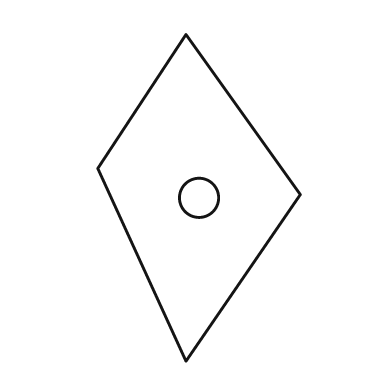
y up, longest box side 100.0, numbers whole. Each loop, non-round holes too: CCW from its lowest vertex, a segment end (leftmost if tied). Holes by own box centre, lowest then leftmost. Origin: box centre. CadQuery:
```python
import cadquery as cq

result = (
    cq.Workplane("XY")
    .moveTo(-4.0, -50.0)
    .lineTo(31.0, 1.0)
    .lineTo(-4.0, 50.0)
    .lineTo(-31.0, 9.0)
    .close()
    .moveTo(0.0, 0.0)
    .circle(6.0)
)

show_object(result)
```